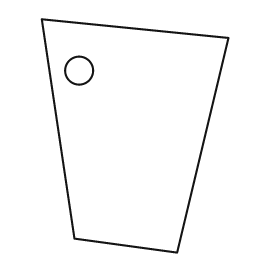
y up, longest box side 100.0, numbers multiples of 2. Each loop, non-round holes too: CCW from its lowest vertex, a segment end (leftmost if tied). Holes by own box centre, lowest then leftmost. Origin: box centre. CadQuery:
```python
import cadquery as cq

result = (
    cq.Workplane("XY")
    .moveTo(18.0, -50.0)
    .lineTo(40.0, 42.0)
    .lineTo(-40.0, 50.0)
    .lineTo(-26.0, -44.0)
    .close()
    .moveTo(-24.0, 28.0)
    .circle(6.0)
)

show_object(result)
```